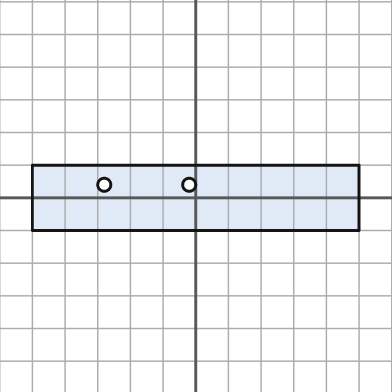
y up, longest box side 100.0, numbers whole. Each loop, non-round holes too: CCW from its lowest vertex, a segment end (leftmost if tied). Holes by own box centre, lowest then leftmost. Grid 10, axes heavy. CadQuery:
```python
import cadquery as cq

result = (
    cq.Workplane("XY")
    .moveTo(-50.0, -10.0)
    .lineTo(50.0, -10.0)
    .lineTo(50.0, 10.0)
    .lineTo(-50.0, 10.0)
    .close()
    .moveTo(-28.0, 4.0)
    .circle(2.0)
    .moveTo(-2.0, 4.0)
    .circle(2.0)
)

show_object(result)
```